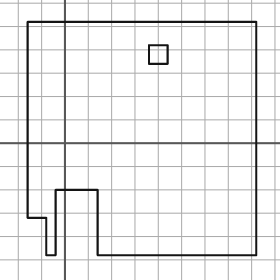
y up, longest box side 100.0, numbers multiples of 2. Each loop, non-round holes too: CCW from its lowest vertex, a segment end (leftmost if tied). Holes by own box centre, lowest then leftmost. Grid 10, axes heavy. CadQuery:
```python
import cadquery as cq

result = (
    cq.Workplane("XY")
    .moveTo(-8.0, -48.0)
    .lineTo(-4.0, -48.0)
    .lineTo(-4.0, -20.0)
    .lineTo(14.0, -20.0)
    .lineTo(14.0, -48.0)
    .lineTo(82.0, -48.0)
    .lineTo(82.0, 52.0)
    .lineTo(-16.0, 52.0)
    .lineTo(-16.0, -32.0)
    .lineTo(-8.0, -32.0)
    .close()
    .moveTo(36.0, 34.0)
    .lineTo(44.0, 34.0)
    .lineTo(44.0, 42.0)
    .lineTo(36.0, 42.0)
    .close()
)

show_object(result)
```